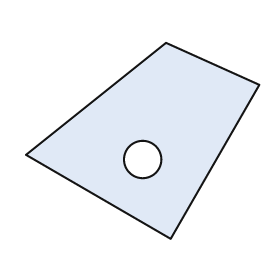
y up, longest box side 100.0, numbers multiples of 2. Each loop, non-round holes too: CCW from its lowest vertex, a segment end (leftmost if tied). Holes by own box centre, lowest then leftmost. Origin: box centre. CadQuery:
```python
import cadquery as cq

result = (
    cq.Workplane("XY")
    .moveTo(12.0, -42.0)
    .lineTo(50.0, 24.0)
    .lineTo(10.0, 42.0)
    .lineTo(-50.0, -6.0)
    .close()
    .moveTo(0.0, -8.0)
    .circle(8.0)
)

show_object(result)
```